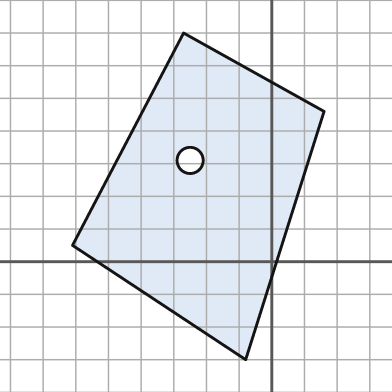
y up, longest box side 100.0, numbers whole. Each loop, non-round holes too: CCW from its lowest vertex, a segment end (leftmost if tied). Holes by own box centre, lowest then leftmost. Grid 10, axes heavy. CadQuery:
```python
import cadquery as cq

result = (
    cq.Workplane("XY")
    .moveTo(-8.0, -30.0)
    .lineTo(16.0, 46.0)
    .lineTo(-27.0, 70.0)
    .lineTo(-61.0, 5.0)
    .close()
    .moveTo(-25.0, 31.0)
    .circle(4.0)
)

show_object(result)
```